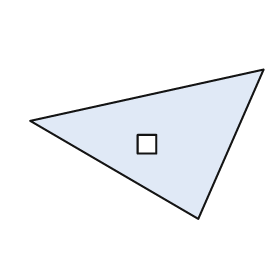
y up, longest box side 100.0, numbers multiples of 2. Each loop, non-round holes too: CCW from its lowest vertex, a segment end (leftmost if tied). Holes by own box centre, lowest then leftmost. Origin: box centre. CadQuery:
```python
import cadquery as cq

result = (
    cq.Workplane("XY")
    .moveTo(22.0, -32.0)
    .lineTo(50.0, 32.0)
    .lineTo(-50.0, 10.0)
    .close()
    .moveTo(-4.0, -4.0)
    .lineTo(4.0, -4.0)
    .lineTo(4.0, 4.0)
    .lineTo(-4.0, 4.0)
    .close()
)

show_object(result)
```